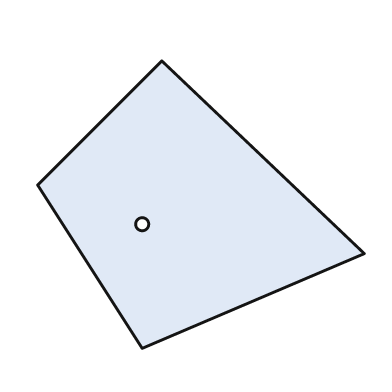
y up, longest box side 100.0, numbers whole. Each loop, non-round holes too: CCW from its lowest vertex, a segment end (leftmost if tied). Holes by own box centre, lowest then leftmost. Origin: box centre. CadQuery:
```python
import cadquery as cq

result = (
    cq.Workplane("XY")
    .moveTo(-18.0, -44.0)
    .lineTo(50.0, -15.0)
    .lineTo(-12.0, 44.0)
    .lineTo(-50.0, 6.0)
    .close()
    .moveTo(-18.0, -6.0)
    .circle(2.0)
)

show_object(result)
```